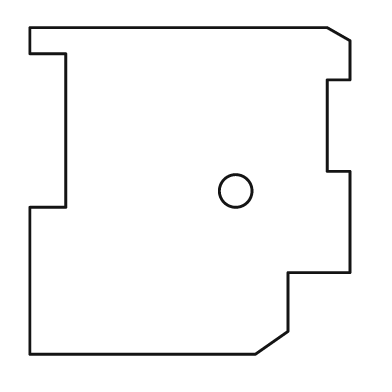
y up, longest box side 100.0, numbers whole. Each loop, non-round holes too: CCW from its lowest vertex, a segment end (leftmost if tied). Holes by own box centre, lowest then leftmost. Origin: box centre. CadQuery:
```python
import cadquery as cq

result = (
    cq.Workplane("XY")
    .moveTo(-49.0, -50.0)
    .lineTo(20.0, -50.0)
    .lineTo(30.0, -43.0)
    .lineTo(30.0, -25.0)
    .lineTo(49.0, -25.0)
    .lineTo(49.0, 6.0)
    .lineTo(42.0, 6.0)
    .lineTo(42.0, 34.0)
    .lineTo(49.0, 34.0)
    .lineTo(49.0, 46.0)
    .lineTo(42.0, 50.0)
    .lineTo(-49.0, 50.0)
    .lineTo(-49.0, 42.0)
    .lineTo(-38.0, 42.0)
    .lineTo(-38.0, -5.0)
    .lineTo(-49.0, -5.0)
    .close()
    .moveTo(14.0, 0.0)
    .circle(5.0)
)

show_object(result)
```